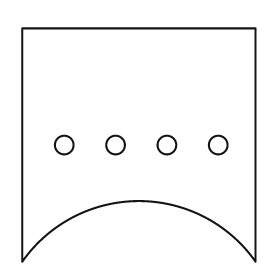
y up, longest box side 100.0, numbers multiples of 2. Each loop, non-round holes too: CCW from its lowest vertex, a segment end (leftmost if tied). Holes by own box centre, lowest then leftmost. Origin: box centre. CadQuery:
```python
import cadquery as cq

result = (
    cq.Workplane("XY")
    .moveTo(-50.0, -50.0)
    .threePointArc((0.0, -24.0), (50.0, -50.0))
    .lineTo(50.0, 50.0)
    .lineTo(-50.0, 50.0)
    .close()
    .moveTo(-32.0, 0.0)
    .circle(4.0)
    .moveTo(-10.0, 0.0)
    .circle(4.0)
    .moveTo(12.0, 0.0)
    .circle(4.0)
    .moveTo(34.0, 0.0)
    .circle(4.0)
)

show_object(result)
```